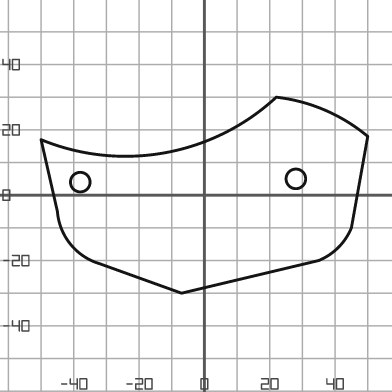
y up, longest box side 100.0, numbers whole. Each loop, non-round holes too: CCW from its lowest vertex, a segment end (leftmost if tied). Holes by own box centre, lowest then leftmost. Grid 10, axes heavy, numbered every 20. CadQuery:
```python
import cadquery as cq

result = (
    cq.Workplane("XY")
    .moveTo(-7.0, -30.0)
    .lineTo(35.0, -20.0)
    .threePointArc((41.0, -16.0), (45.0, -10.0))
    .lineTo(50.0, 18.0)
    .threePointArc((37.0, 26.0), (22.0, 30.0))
    .threePointArc((-12.0, 13.0), (-50.0, 17.0))
    .lineTo(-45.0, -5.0)
    .threePointArc((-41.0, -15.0), (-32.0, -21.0))
    .close()
    .moveTo(-38.0, 4.0)
    .circle(3.0)
    .moveTo(28.0, 5.0)
    .circle(3.0)
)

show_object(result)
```